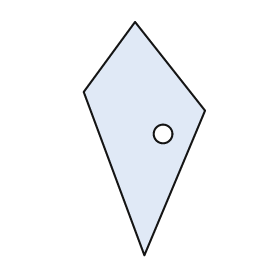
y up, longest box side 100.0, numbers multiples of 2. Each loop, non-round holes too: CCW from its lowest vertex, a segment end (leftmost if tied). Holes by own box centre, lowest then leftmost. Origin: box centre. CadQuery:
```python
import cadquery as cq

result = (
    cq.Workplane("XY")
    .moveTo(0.0, -50.0)
    .lineTo(26.0, 12.0)
    .lineTo(-4.0, 50.0)
    .lineTo(-26.0, 20.0)
    .close()
    .moveTo(8.0, 2.0)
    .circle(4.0)
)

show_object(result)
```